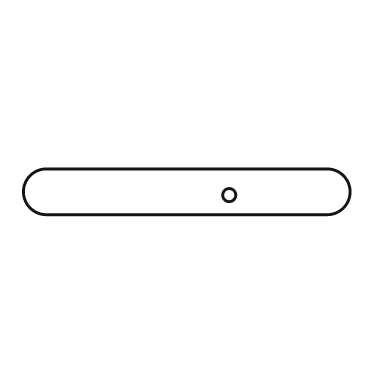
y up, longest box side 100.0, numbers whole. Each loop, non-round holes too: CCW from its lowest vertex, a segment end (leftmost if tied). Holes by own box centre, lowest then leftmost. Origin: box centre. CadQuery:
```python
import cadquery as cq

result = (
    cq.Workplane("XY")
    .moveTo(-43.0, -7.0)
    .lineTo(43.0, -7.0)
    .threePointArc((50.0, 0.0), (43.0, 7.0))
    .lineTo(-43.0, 7.0)
    .threePointArc((-50.0, 0.0), (-43.0, -7.0))
    .close()
    .moveTo(13.0, -1.0)
    .circle(2.0)
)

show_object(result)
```